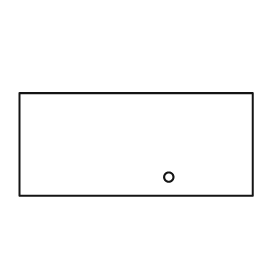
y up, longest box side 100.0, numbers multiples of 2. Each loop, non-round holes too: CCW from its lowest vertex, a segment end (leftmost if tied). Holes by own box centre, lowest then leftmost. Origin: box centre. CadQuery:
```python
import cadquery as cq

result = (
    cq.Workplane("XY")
    .moveTo(-50.0, -22.0)
    .lineTo(50.0, -22.0)
    .lineTo(50.0, 22.0)
    .lineTo(-50.0, 22.0)
    .close()
    .moveTo(14.0, -14.0)
    .circle(2.0)
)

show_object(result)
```